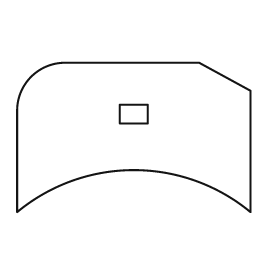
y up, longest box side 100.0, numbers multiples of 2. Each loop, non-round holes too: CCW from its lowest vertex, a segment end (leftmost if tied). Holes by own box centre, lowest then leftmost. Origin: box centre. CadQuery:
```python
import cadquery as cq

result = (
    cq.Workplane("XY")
    .moveTo(-50.0, -32.0)
    .threePointArc((0.0, -14.0), (50.0, -32.0))
    .lineTo(50.0, 20.0)
    .lineTo(28.0, 32.0)
    .lineTo(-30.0, 32.0)
    .threePointArc((-44.0, 26.0), (-50.0, 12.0))
    .close()
    .moveTo(-6.0, 6.0)
    .lineTo(6.0, 6.0)
    .lineTo(6.0, 14.0)
    .lineTo(-6.0, 14.0)
    .close()
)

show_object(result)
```